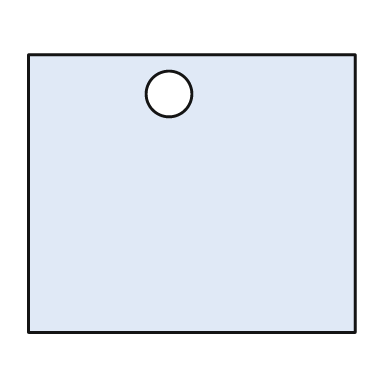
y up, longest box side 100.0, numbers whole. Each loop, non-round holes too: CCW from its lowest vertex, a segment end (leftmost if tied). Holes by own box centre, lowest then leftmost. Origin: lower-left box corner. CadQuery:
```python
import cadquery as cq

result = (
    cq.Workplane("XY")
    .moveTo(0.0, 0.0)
    .lineTo(100.0, 0.0)
    .lineTo(100.0, 85.0)
    .lineTo(0.0, 85.0)
    .close()
    .moveTo(43.0, 73.0)
    .circle(7.0)
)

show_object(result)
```